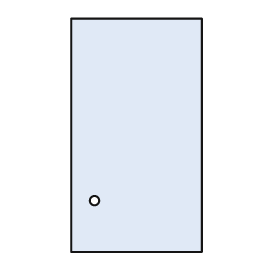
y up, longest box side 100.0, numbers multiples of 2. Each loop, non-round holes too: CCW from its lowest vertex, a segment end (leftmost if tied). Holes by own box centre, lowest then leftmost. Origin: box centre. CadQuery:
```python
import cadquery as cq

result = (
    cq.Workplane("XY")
    .moveTo(-28.0, -50.0)
    .lineTo(28.0, -50.0)
    .lineTo(28.0, 50.0)
    .lineTo(-28.0, 50.0)
    .close()
    .moveTo(-18.0, -28.0)
    .circle(2.0)
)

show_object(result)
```